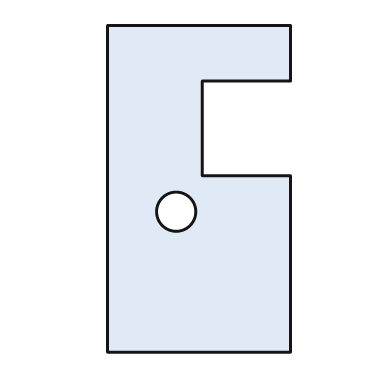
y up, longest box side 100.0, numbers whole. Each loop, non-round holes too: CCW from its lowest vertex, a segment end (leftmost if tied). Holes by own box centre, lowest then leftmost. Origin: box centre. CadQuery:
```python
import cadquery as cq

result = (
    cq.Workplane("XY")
    .moveTo(-28.0, -50.0)
    .lineTo(28.0, -50.0)
    .lineTo(28.0, 4.0)
    .lineTo(1.0, 4.0)
    .lineTo(1.0, 33.0)
    .lineTo(28.0, 33.0)
    .lineTo(28.0, 50.0)
    .lineTo(-28.0, 50.0)
    .close()
    .moveTo(-7.0, -7.0)
    .circle(6.0)
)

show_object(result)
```